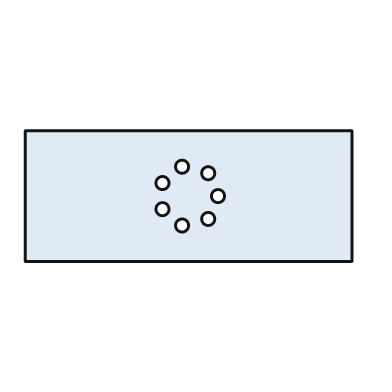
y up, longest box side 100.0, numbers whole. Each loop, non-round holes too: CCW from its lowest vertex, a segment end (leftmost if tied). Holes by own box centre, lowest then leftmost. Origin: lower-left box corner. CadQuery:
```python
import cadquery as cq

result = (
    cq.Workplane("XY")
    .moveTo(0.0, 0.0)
    .lineTo(100.0, 0.0)
    .lineTo(100.0, 40.0)
    .lineTo(0.0, 40.0)
    .close()
    .moveTo(48.0, 11.0)
    .circle(2.0)
    .moveTo(56.0, 13.0)
    .circle(2.0)
    .moveTo(42.0, 16.0)
    .circle(2.0)
    .moveTo(59.0, 20.0)
    .circle(2.0)
    .moveTo(42.0, 24.0)
    .circle(2.0)
    .moveTo(56.0, 27.0)
    .circle(2.0)
    .moveTo(48.0, 29.0)
    .circle(2.0)
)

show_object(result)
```